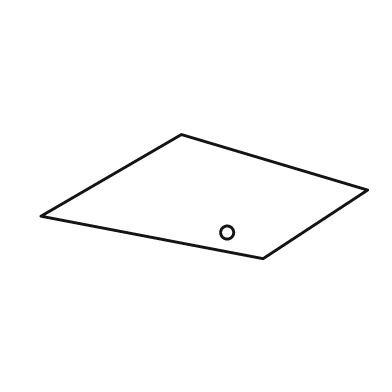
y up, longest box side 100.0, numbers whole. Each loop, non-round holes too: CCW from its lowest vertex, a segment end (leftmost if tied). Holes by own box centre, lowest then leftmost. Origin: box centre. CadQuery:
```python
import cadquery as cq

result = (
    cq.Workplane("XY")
    .moveTo(18.0, -19.0)
    .lineTo(50.0, 2.0)
    .lineTo(-7.0, 19.0)
    .lineTo(-50.0, -6.0)
    .close()
    .moveTo(7.0, -11.0)
    .circle(2.0)
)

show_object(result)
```